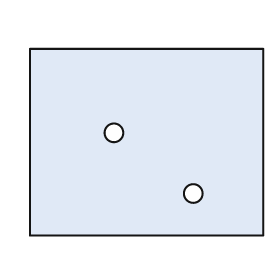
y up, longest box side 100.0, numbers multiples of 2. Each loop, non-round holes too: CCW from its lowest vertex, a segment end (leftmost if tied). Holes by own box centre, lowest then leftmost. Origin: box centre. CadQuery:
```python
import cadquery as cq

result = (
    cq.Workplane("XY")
    .moveTo(-50.0, -40.0)
    .lineTo(50.0, -40.0)
    .lineTo(50.0, 40.0)
    .lineTo(-50.0, 40.0)
    .close()
    .moveTo(20.0, -22.0)
    .circle(4.0)
    .moveTo(-14.0, 4.0)
    .circle(4.0)
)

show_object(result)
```